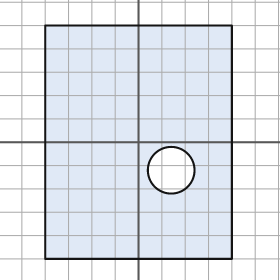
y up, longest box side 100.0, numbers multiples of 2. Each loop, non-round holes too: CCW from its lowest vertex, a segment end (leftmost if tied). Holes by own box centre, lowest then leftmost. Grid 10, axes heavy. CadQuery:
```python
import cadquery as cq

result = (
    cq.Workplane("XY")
    .moveTo(-40.0, -50.0)
    .lineTo(40.0, -50.0)
    .lineTo(40.0, 50.0)
    .lineTo(-40.0, 50.0)
    .close()
    .moveTo(14.0, -12.0)
    .circle(10.0)
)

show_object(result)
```